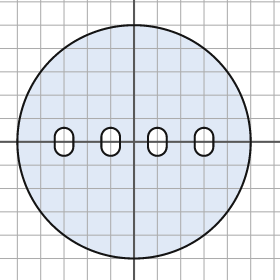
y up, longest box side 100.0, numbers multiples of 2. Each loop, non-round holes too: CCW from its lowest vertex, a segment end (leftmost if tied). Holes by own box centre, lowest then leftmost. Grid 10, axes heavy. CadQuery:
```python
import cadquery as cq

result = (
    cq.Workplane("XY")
    .moveTo(0.0, 0.0)
    .circle(50.0)
    .moveTo(-34.0, -2.0)
    .threePointArc((-30.0, -6.0), (-26.0, -2.0))
    .lineTo(-26.0, 2.0)
    .threePointArc((-30.0, 6.0), (-34.0, 2.0))
    .close()
    .moveTo(-14.0, -2.0)
    .threePointArc((-10.0, -6.0), (-6.0, -2.0))
    .lineTo(-6.0, 2.0)
    .threePointArc((-10.0, 6.0), (-14.0, 2.0))
    .close()
    .moveTo(6.0, -2.0)
    .threePointArc((10.0, -6.0), (14.0, -2.0))
    .lineTo(14.0, 2.0)
    .threePointArc((10.0, 6.0), (6.0, 2.0))
    .close()
    .moveTo(26.0, -2.0)
    .threePointArc((30.0, -6.0), (34.0, -2.0))
    .lineTo(34.0, 2.0)
    .threePointArc((30.0, 6.0), (26.0, 2.0))
    .close()
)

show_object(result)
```